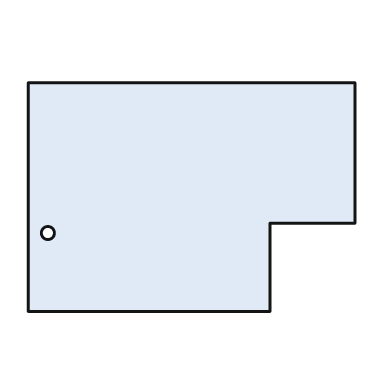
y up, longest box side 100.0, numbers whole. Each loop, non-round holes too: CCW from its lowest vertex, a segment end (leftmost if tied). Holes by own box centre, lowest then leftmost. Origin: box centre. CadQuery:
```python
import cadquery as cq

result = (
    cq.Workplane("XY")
    .moveTo(-50.0, -35.0)
    .lineTo(24.0, -35.0)
    .lineTo(24.0, -8.0)
    .lineTo(50.0, -8.0)
    .lineTo(50.0, 35.0)
    .lineTo(-50.0, 35.0)
    .close()
    .moveTo(-44.0, -11.0)
    .circle(2.0)
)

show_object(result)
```